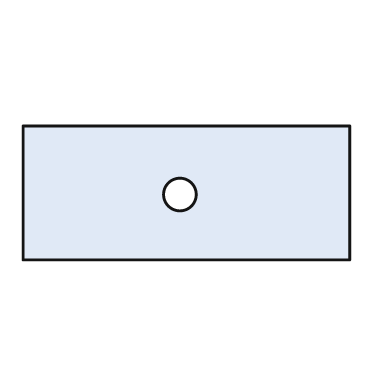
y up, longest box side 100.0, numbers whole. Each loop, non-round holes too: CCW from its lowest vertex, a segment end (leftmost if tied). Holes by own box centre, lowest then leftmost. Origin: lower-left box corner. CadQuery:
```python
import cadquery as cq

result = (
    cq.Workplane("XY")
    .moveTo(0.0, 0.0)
    .lineTo(100.0, 0.0)
    .lineTo(100.0, 41.0)
    .lineTo(0.0, 41.0)
    .close()
    .moveTo(48.0, 20.0)
    .circle(5.0)
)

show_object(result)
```